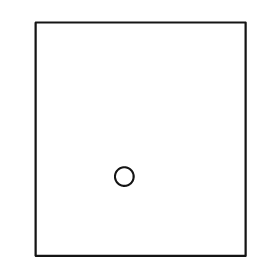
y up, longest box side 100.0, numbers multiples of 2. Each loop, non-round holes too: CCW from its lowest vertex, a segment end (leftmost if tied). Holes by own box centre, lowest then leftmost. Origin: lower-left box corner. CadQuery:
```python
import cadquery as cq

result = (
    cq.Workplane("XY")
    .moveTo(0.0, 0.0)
    .lineTo(90.0, 0.0)
    .lineTo(90.0, 100.0)
    .lineTo(0.0, 100.0)
    .close()
    .moveTo(38.0, 34.0)
    .circle(4.0)
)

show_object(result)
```